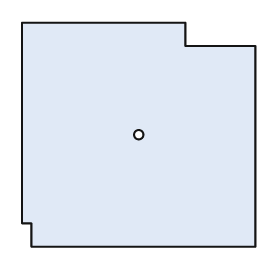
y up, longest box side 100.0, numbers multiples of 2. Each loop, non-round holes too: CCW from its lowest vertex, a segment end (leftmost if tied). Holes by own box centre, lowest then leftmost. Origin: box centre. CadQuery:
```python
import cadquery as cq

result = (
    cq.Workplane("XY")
    .moveTo(-46.0, -48.0)
    .lineTo(50.0, -48.0)
    .lineTo(50.0, 38.0)
    .lineTo(20.0, 38.0)
    .lineTo(20.0, 48.0)
    .lineTo(-50.0, 48.0)
    .lineTo(-50.0, -38.0)
    .lineTo(-46.0, -38.0)
    .close()
    .moveTo(0.0, 0.0)
    .circle(2.0)
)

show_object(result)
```